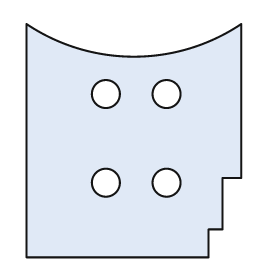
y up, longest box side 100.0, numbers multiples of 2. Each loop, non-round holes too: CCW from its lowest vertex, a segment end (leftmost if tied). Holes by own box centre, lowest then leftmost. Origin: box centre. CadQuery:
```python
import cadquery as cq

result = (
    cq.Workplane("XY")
    .moveTo(-46.0, -50.0)
    .lineTo(32.0, -50.0)
    .lineTo(32.0, -38.0)
    .lineTo(38.0, -38.0)
    .lineTo(38.0, -16.0)
    .lineTo(46.0, -16.0)
    .lineTo(46.0, 50.0)
    .threePointArc((0.0, 36.0), (-46.0, 50.0))
    .close()
    .moveTo(-12.0, -18.0)
    .circle(6.0)
    .moveTo(14.0, -18.0)
    .circle(6.0)
    .moveTo(-12.0, 20.0)
    .circle(6.0)
    .moveTo(14.0, 20.0)
    .circle(6.0)
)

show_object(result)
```